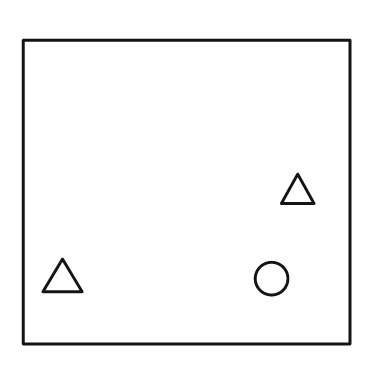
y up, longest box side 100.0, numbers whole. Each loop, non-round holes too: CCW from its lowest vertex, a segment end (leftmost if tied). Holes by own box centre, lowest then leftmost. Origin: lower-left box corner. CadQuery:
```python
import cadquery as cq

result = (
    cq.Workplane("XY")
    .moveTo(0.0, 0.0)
    .lineTo(100.0, 0.0)
    .lineTo(100.0, 93.0)
    .lineTo(0.0, 93.0)
    .close()
    .moveTo(76.0, 20.0)
    .circle(5.0)
    .moveTo(6.0, 16.0)
    .lineTo(18.0, 16.0)
    .lineTo(12.0, 26.0)
    .close()
    .moveTo(79.0, 43.0)
    .lineTo(89.0, 43.0)
    .lineTo(84.0, 52.0)
    .close()
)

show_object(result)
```